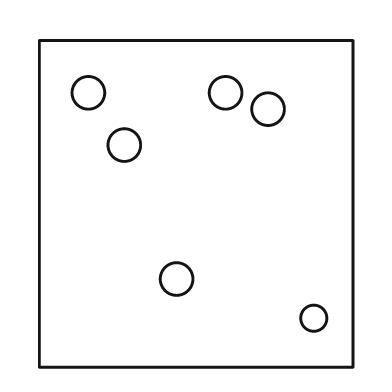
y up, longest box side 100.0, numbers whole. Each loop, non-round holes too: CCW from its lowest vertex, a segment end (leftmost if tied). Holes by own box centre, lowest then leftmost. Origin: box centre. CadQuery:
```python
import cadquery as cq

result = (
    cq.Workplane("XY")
    .moveTo(-48.0, -50.0)
    .lineTo(48.0, -50.0)
    .lineTo(48.0, 50.0)
    .lineTo(-48.0, 50.0)
    .close()
    .moveTo(36.0, -35.0)
    .circle(4.0)
    .moveTo(-6.0, -23.0)
    .circle(5.0)
    .moveTo(-22.0, 18.0)
    .circle(5.0)
    .moveTo(22.0, 29.0)
    .circle(5.0)
    .moveTo(-33.0, 34.0)
    .circle(5.0)
    .moveTo(9.0, 34.0)
    .circle(5.0)
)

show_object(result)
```